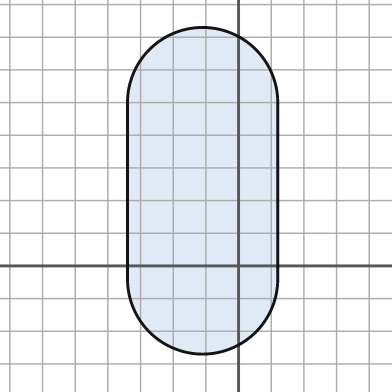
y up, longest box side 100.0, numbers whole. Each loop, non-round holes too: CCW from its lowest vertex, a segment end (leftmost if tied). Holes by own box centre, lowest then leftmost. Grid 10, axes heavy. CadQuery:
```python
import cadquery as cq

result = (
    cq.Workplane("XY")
    .moveTo(-34.0, -4.0)
    .threePointArc((-11.0, -27.0), (12.0, -4.0))
    .lineTo(12.0, 50.0)
    .threePointArc((-11.0, 73.0), (-34.0, 50.0))
    .close()
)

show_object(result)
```